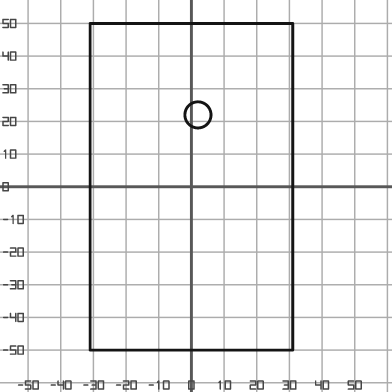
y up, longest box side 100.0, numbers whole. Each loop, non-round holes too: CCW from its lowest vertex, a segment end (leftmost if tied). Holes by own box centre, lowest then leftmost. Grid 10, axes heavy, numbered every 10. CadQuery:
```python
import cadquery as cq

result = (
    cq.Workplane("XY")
    .moveTo(-31.0, -50.0)
    .lineTo(31.0, -50.0)
    .lineTo(31.0, 50.0)
    .lineTo(-31.0, 50.0)
    .close()
    .moveTo(2.0, 22.0)
    .circle(4.0)
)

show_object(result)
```